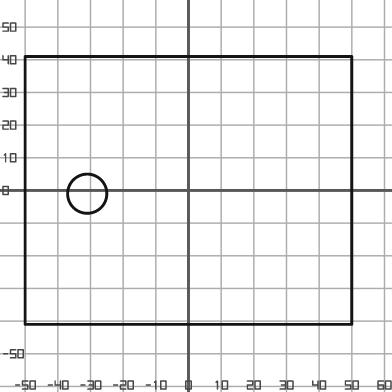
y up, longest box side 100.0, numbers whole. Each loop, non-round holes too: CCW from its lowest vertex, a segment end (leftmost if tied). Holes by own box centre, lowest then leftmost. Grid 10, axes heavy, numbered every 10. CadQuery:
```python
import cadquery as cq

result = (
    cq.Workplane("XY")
    .moveTo(-50.0, -41.0)
    .lineTo(50.0, -41.0)
    .lineTo(50.0, 41.0)
    .lineTo(-50.0, 41.0)
    .close()
    .moveTo(-31.0, -1.0)
    .circle(6.0)
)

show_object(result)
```